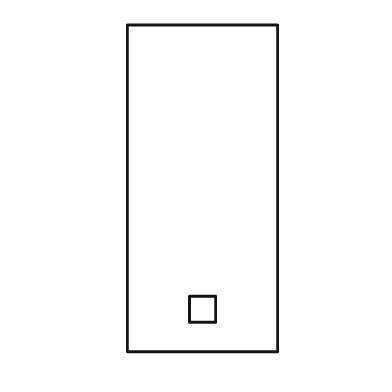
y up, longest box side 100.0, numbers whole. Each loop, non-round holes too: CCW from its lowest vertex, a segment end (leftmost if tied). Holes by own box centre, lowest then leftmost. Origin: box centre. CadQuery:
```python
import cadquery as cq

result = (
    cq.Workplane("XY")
    .moveTo(-23.0, -50.0)
    .lineTo(23.0, -50.0)
    .lineTo(23.0, 50.0)
    .lineTo(-23.0, 50.0)
    .close()
    .moveTo(-4.0, -41.0)
    .lineTo(4.0, -41.0)
    .lineTo(4.0, -33.0)
    .lineTo(-4.0, -33.0)
    .close()
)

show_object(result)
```